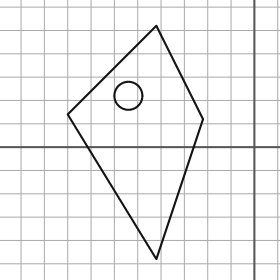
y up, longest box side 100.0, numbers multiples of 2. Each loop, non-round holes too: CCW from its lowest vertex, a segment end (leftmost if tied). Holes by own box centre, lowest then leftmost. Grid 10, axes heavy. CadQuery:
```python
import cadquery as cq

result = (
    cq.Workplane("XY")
    .moveTo(-42.0, -48.0)
    .lineTo(-22.0, 12.0)
    .lineTo(-42.0, 52.0)
    .lineTo(-80.0, 14.0)
    .close()
    .moveTo(-54.0, 22.0)
    .circle(6.0)
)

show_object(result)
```